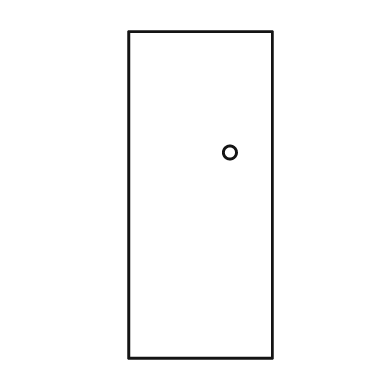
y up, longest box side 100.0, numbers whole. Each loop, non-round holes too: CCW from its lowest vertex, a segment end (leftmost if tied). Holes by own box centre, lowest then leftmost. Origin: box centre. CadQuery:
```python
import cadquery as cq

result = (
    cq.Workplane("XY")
    .moveTo(-22.0, -50.0)
    .lineTo(22.0, -50.0)
    .lineTo(22.0, 50.0)
    .lineTo(-22.0, 50.0)
    .close()
    .moveTo(9.0, 13.0)
    .circle(2.0)
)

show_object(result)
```